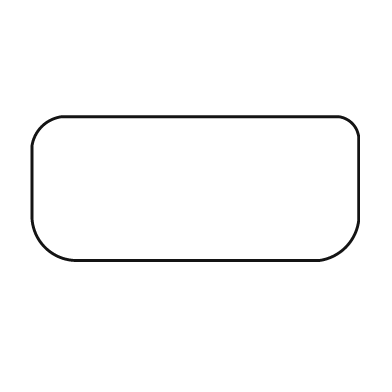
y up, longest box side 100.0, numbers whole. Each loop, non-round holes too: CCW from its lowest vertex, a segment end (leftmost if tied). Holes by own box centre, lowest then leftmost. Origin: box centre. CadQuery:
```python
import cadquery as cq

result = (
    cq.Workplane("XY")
    .moveTo(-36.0, -22.0)
    .lineTo(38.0, -22.0)
    .threePointArc((46.0, -18.0), (50.0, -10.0))
    .lineTo(50.0, 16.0)
    .threePointArc((48.0, 20.0), (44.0, 22.0))
    .lineTo(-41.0, 22.0)
    .threePointArc((-47.0, 19.0), (-50.0, 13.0))
    .lineTo(-50.0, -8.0)
    .threePointArc((-46.0, -18.0), (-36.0, -22.0))
    .close()
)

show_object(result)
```